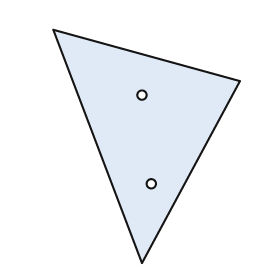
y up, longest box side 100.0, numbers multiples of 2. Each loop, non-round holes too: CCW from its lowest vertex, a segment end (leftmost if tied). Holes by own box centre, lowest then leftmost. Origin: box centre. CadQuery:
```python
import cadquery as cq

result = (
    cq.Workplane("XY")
    .moveTo(-2.0, -50.0)
    .lineTo(40.0, 28.0)
    .lineTo(-40.0, 50.0)
    .close()
    .moveTo(2.0, -16.0)
    .circle(2.0)
    .moveTo(-2.0, 22.0)
    .circle(2.0)
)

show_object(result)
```